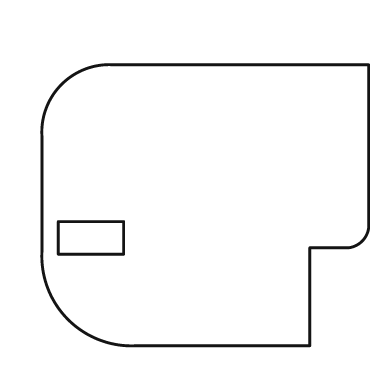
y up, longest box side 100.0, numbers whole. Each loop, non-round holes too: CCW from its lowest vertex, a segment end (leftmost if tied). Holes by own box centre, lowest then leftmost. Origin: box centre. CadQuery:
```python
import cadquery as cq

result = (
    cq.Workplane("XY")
    .moveTo(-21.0, -43.0)
    .lineTo(32.0, -43.0)
    .lineTo(32.0, -13.0)
    .lineTo(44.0, -13.0)
    .threePointArc((48.0, -11.0), (50.0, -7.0))
    .lineTo(50.0, 43.0)
    .lineTo(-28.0, 43.0)
    .threePointArc((-44.0, 37.0), (-50.0, 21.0))
    .lineTo(-50.0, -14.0)
    .threePointArc((-42.0, -35.0), (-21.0, -43.0))
    .close()
    .moveTo(-45.0, -15.0)
    .lineTo(-25.0, -15.0)
    .lineTo(-25.0, -5.0)
    .lineTo(-45.0, -5.0)
    .close()
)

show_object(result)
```